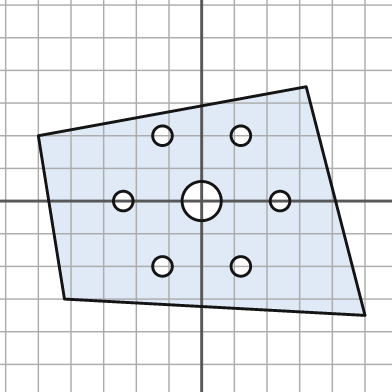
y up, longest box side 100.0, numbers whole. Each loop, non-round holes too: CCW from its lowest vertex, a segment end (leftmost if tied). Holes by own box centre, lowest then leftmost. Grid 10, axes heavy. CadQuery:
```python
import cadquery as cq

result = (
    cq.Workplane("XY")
    .moveTo(50.0, -35.0)
    .lineTo(32.0, 35.0)
    .lineTo(-50.0, 20.0)
    .lineTo(-42.0, -30.0)
    .close()
    .moveTo(-12.0, -20.0)
    .circle(3.0)
    .moveTo(12.0, -20.0)
    .circle(3.0)
    .moveTo(-24.0, 0.0)
    .circle(3.0)
    .moveTo(0.0, 0.0)
    .circle(6.0)
    .moveTo(24.0, 0.0)
    .circle(3.0)
    .moveTo(-12.0, 20.0)
    .circle(3.0)
    .moveTo(12.0, 20.0)
    .circle(3.0)
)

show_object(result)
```